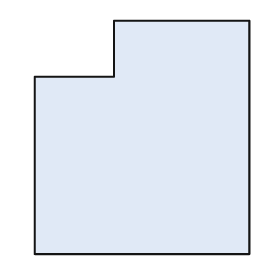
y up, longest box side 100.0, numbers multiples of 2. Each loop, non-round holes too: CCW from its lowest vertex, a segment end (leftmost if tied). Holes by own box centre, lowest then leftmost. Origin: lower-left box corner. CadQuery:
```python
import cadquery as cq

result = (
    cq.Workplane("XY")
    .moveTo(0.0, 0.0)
    .lineTo(92.0, 0.0)
    .lineTo(92.0, 100.0)
    .lineTo(34.0, 100.0)
    .lineTo(34.0, 76.0)
    .lineTo(0.0, 76.0)
    .close()
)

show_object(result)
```